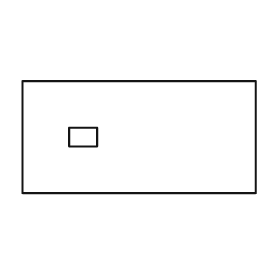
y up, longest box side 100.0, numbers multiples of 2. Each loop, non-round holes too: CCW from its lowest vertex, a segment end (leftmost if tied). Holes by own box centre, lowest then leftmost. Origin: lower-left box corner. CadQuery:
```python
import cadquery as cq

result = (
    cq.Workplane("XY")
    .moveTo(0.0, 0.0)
    .lineTo(100.0, 0.0)
    .lineTo(100.0, 48.0)
    .lineTo(0.0, 48.0)
    .close()
    .moveTo(20.0, 20.0)
    .lineTo(32.0, 20.0)
    .lineTo(32.0, 28.0)
    .lineTo(20.0, 28.0)
    .close()
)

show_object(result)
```